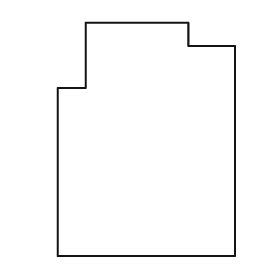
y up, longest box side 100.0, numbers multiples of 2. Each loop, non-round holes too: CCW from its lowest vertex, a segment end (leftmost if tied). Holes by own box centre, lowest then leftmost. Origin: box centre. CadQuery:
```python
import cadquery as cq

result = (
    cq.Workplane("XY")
    .moveTo(-38.0, -50.0)
    .lineTo(38.0, -50.0)
    .lineTo(38.0, 40.0)
    .lineTo(18.0, 40.0)
    .lineTo(18.0, 50.0)
    .lineTo(-26.0, 50.0)
    .lineTo(-26.0, 22.0)
    .lineTo(-38.0, 22.0)
    .close()
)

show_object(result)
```